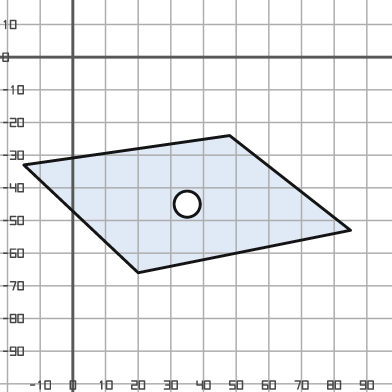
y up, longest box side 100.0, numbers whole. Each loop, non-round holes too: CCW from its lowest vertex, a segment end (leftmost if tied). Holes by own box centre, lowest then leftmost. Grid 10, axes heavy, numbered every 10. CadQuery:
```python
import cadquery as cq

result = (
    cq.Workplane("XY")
    .moveTo(20.0, -66.0)
    .lineTo(85.0, -53.0)
    .lineTo(48.0, -24.0)
    .lineTo(-15.0, -33.0)
    .close()
    .moveTo(35.0, -45.0)
    .circle(4.0)
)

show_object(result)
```